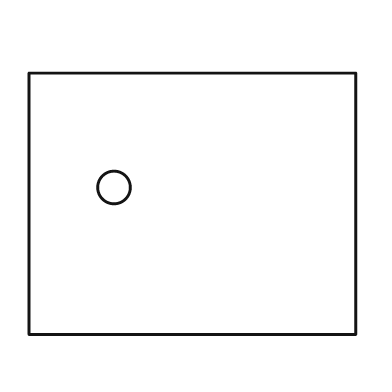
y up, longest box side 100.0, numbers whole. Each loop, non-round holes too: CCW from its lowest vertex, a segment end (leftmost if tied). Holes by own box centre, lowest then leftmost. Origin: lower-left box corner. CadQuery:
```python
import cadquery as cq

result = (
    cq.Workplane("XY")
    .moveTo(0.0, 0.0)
    .lineTo(100.0, 0.0)
    .lineTo(100.0, 80.0)
    .lineTo(0.0, 80.0)
    .close()
    .moveTo(26.0, 45.0)
    .circle(5.0)
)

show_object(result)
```